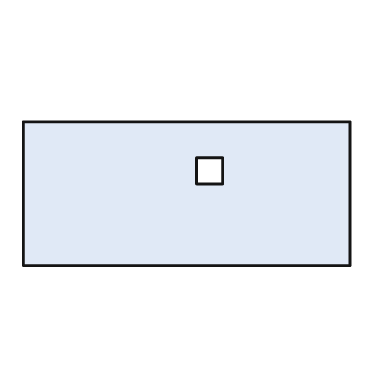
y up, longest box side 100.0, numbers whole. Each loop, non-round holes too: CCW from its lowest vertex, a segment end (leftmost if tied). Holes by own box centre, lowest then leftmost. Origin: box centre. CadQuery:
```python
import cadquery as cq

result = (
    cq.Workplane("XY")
    .moveTo(-50.0, -22.0)
    .lineTo(50.0, -22.0)
    .lineTo(50.0, 22.0)
    .lineTo(-50.0, 22.0)
    .close()
    .moveTo(3.0, 3.0)
    .lineTo(11.0, 3.0)
    .lineTo(11.0, 11.0)
    .lineTo(3.0, 11.0)
    .close()
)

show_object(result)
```